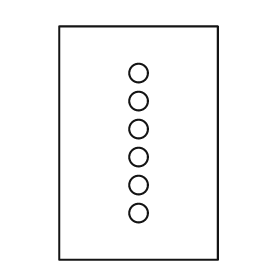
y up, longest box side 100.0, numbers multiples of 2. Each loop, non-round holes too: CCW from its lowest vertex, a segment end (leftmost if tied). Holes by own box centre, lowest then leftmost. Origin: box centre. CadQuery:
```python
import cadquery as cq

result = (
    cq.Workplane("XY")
    .moveTo(-34.0, -50.0)
    .lineTo(34.0, -50.0)
    .lineTo(34.0, 50.0)
    .lineTo(-34.0, 50.0)
    .close()
    .moveTo(0.0, -30.0)
    .circle(4.0)
    .moveTo(0.0, -18.0)
    .circle(4.0)
    .moveTo(0.0, -6.0)
    .circle(4.0)
    .moveTo(0.0, 6.0)
    .circle(4.0)
    .moveTo(0.0, 18.0)
    .circle(4.0)
    .moveTo(0.0, 30.0)
    .circle(4.0)
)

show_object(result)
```